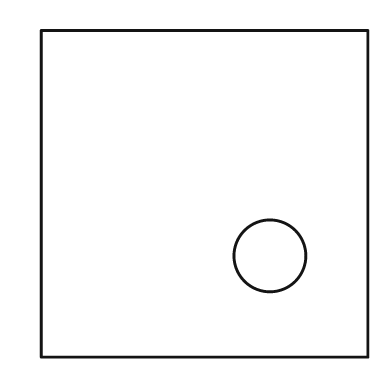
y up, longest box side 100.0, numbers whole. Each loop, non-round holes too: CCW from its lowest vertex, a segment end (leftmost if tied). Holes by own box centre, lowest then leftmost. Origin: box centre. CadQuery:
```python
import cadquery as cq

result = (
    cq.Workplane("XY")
    .moveTo(-50.0, -50.0)
    .lineTo(50.0, -50.0)
    .lineTo(50.0, 50.0)
    .lineTo(-50.0, 50.0)
    .close()
    .moveTo(20.0, -19.0)
    .circle(11.0)
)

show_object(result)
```